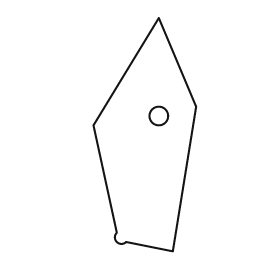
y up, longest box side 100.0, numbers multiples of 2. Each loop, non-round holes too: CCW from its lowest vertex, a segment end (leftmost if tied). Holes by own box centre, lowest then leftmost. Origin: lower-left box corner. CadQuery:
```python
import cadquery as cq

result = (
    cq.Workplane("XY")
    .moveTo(34.0, 0.0)
    .lineTo(44.0, 62.0)
    .lineTo(28.0, 100.0)
    .lineTo(0.0, 54.0)
    .lineTo(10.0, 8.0)
    .threePointArc((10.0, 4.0), (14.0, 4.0))
    .close()
    .moveTo(28.0, 58.0)
    .circle(4.0)
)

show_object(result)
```